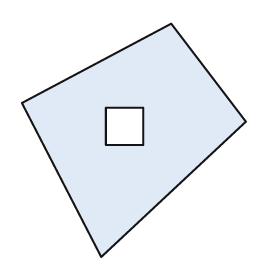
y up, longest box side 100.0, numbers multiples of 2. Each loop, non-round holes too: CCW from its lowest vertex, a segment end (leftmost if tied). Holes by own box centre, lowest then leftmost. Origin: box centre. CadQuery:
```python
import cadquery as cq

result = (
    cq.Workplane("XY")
    .moveTo(-14.0, -50.0)
    .lineTo(48.0, 8.0)
    .lineTo(16.0, 50.0)
    .lineTo(-48.0, 16.0)
    .close()
    .moveTo(-12.0, -2.0)
    .lineTo(4.0, -2.0)
    .lineTo(4.0, 14.0)
    .lineTo(-12.0, 14.0)
    .close()
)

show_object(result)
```